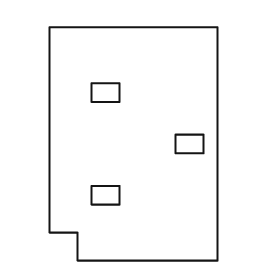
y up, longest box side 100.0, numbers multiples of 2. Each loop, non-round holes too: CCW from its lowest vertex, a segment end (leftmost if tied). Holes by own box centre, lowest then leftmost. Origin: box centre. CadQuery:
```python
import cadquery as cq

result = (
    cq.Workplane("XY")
    .moveTo(-24.0, -50.0)
    .lineTo(36.0, -50.0)
    .lineTo(36.0, 50.0)
    .lineTo(-36.0, 50.0)
    .lineTo(-36.0, -38.0)
    .lineTo(-24.0, -38.0)
    .close()
    .moveTo(-18.0, -26.0)
    .lineTo(-6.0, -26.0)
    .lineTo(-6.0, -18.0)
    .lineTo(-18.0, -18.0)
    .close()
    .moveTo(18.0, -4.0)
    .lineTo(30.0, -4.0)
    .lineTo(30.0, 4.0)
    .lineTo(18.0, 4.0)
    .close()
    .moveTo(-18.0, 18.0)
    .lineTo(-6.0, 18.0)
    .lineTo(-6.0, 26.0)
    .lineTo(-18.0, 26.0)
    .close()
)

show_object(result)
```